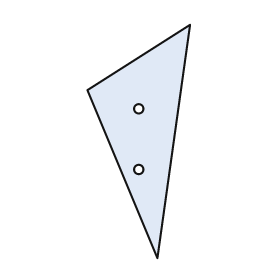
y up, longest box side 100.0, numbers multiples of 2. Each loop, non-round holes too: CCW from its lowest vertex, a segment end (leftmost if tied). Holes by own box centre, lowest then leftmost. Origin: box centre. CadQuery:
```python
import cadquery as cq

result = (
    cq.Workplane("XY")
    .moveTo(8.0, -50.0)
    .lineTo(22.0, 50.0)
    .lineTo(-22.0, 22.0)
    .close()
    .moveTo(0.0, -12.0)
    .circle(2.0)
    .moveTo(0.0, 14.0)
    .circle(2.0)
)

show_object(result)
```